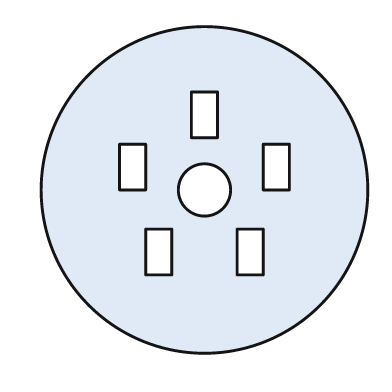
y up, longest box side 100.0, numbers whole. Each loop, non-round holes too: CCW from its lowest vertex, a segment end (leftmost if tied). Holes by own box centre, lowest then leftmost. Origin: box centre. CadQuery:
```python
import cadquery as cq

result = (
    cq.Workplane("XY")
    .moveTo(0.0, 0.0)
    .circle(50.0)
    .moveTo(-18.0, -26.0)
    .lineTo(-10.0, -26.0)
    .lineTo(-10.0, -12.0)
    .lineTo(-18.0, -12.0)
    .close()
    .moveTo(10.0, -26.0)
    .lineTo(18.0, -26.0)
    .lineTo(18.0, -12.0)
    .lineTo(10.0, -12.0)
    .close()
    .moveTo(0.0, 0.0)
    .circle(8.0)
    .moveTo(-26.0, 0.0)
    .lineTo(-18.0, 0.0)
    .lineTo(-18.0, 14.0)
    .lineTo(-26.0, 14.0)
    .close()
    .moveTo(18.0, 0.0)
    .lineTo(26.0, 0.0)
    .lineTo(26.0, 14.0)
    .lineTo(18.0, 14.0)
    .close()
    .moveTo(-4.0, 16.0)
    .lineTo(4.0, 16.0)
    .lineTo(4.0, 30.0)
    .lineTo(-4.0, 30.0)
    .close()
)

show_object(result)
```